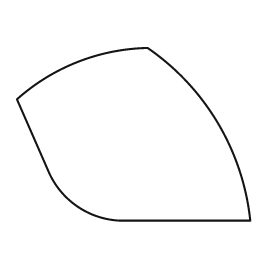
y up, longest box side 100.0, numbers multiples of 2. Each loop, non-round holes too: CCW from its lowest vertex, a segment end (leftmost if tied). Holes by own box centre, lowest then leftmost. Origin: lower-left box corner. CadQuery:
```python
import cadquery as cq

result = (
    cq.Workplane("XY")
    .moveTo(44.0, 0.0)
    .lineTo(100.0, 0.0)
    .threePointArc((86.0, 42.0), (56.0, 74.0))
    .threePointArc((26.0, 68.0), (0.0, 52.0))
    .lineTo(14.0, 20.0)
    .threePointArc((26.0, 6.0), (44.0, 0.0))
    .close()
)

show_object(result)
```